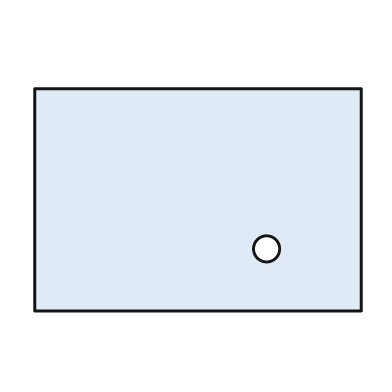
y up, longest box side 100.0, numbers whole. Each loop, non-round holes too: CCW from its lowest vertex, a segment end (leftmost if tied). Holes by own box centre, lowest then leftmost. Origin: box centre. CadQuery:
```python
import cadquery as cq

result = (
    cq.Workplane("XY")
    .moveTo(-50.0, -34.0)
    .lineTo(50.0, -34.0)
    .lineTo(50.0, 34.0)
    .lineTo(-50.0, 34.0)
    .close()
    .moveTo(21.0, -15.0)
    .circle(4.0)
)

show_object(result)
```